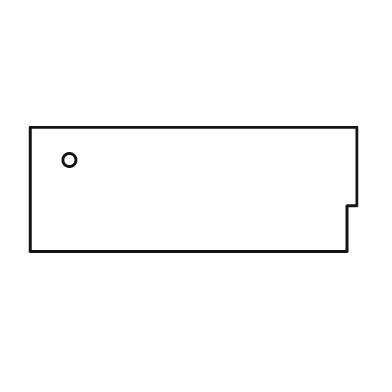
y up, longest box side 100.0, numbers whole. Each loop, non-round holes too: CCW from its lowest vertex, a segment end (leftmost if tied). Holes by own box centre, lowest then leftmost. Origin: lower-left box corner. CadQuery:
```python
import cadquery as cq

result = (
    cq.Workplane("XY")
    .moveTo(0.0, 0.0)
    .lineTo(97.0, 0.0)
    .lineTo(97.0, 14.0)
    .lineTo(100.0, 14.0)
    .lineTo(100.0, 38.0)
    .lineTo(0.0, 38.0)
    .close()
    .moveTo(12.0, 28.0)
    .circle(2.0)
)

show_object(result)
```